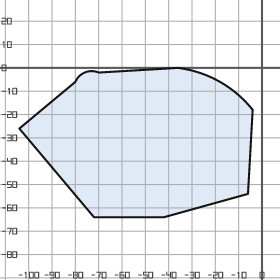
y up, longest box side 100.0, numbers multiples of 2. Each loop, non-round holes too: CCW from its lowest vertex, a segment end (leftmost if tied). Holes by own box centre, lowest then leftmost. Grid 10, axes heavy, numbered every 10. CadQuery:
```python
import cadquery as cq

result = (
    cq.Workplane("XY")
    .moveTo(-72.0, -64.0)
    .lineTo(-42.0, -64.0)
    .lineTo(-6.0, -54.0)
    .lineTo(-4.0, -18.0)
    .threePointArc((-18.0, -6.0), (-36.0, 0.0))
    .lineTo(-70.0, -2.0)
    .threePointArc((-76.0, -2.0), (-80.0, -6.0))
    .lineTo(-104.0, -26.0)
    .close()
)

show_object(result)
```